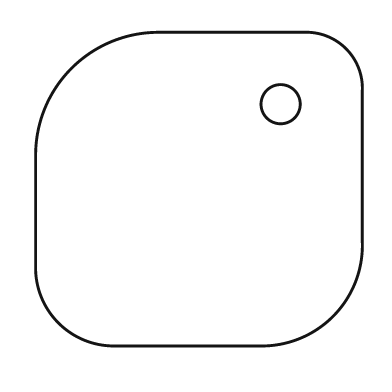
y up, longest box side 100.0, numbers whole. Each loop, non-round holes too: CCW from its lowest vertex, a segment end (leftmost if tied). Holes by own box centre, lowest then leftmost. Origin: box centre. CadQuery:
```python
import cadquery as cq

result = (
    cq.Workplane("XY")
    .moveTo(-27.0, -48.0)
    .lineTo(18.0, -48.0)
    .threePointArc((41.0, -39.0), (50.0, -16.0))
    .lineTo(50.0, 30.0)
    .threePointArc((45.0, 43.0), (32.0, 48.0))
    .lineTo(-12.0, 48.0)
    .threePointArc((-39.0, 37.0), (-50.0, 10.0))
    .lineTo(-50.0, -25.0)
    .threePointArc((-43.0, -41.0), (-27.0, -48.0))
    .close()
    .moveTo(25.0, 26.0)
    .circle(6.0)
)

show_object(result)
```